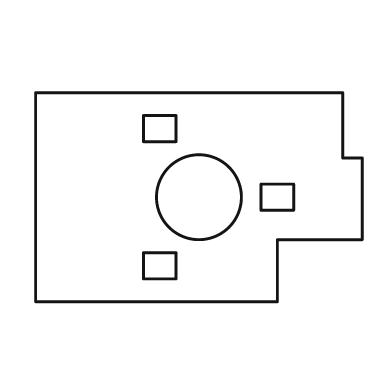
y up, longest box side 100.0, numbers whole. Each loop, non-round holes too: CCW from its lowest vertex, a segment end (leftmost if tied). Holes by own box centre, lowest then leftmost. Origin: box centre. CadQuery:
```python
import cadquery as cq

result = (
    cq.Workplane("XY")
    .moveTo(-50.0, -32.0)
    .lineTo(24.0, -32.0)
    .lineTo(24.0, -13.0)
    .lineTo(50.0, -13.0)
    .lineTo(50.0, 12.0)
    .lineTo(44.0, 12.0)
    .lineTo(44.0, 32.0)
    .lineTo(-50.0, 32.0)
    .close()
    .moveTo(-17.0, -25.0)
    .lineTo(-7.0, -25.0)
    .lineTo(-7.0, -17.0)
    .lineTo(-17.0, -17.0)
    .close()
    .moveTo(0.0, 0.0)
    .circle(13.0)
    .moveTo(19.0, -4.0)
    .lineTo(29.0, -4.0)
    .lineTo(29.0, 4.0)
    .lineTo(19.0, 4.0)
    .close()
    .moveTo(-17.0, 17.0)
    .lineTo(-7.0, 17.0)
    .lineTo(-7.0, 25.0)
    .lineTo(-17.0, 25.0)
    .close()
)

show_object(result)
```